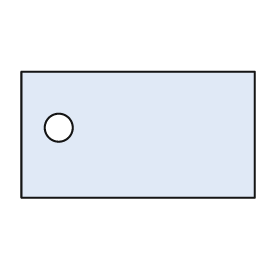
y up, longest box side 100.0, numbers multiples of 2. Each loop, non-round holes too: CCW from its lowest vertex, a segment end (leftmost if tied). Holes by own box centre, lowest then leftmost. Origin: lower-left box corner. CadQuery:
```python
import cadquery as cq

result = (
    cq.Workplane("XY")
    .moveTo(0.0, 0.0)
    .lineTo(100.0, 0.0)
    .lineTo(100.0, 54.0)
    .lineTo(0.0, 54.0)
    .close()
    .moveTo(16.0, 30.0)
    .circle(6.0)
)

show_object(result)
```